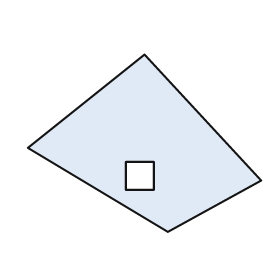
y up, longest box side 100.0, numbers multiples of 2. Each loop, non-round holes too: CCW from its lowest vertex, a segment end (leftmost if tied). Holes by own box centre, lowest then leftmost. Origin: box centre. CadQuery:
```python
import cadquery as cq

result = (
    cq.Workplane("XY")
    .moveTo(10.0, -38.0)
    .lineTo(50.0, -16.0)
    .lineTo(0.0, 38.0)
    .lineTo(-50.0, -2.0)
    .close()
    .moveTo(-8.0, -20.0)
    .lineTo(4.0, -20.0)
    .lineTo(4.0, -8.0)
    .lineTo(-8.0, -8.0)
    .close()
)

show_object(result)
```